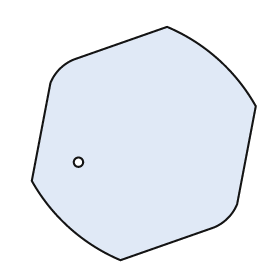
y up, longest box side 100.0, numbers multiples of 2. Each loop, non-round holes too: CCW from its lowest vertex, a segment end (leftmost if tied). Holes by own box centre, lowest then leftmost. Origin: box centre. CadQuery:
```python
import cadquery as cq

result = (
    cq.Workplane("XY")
    .moveTo(-10.0, -50.0)
    .lineTo(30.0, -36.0)
    .threePointArc((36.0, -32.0), (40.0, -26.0))
    .lineTo(48.0, 16.0)
    .threePointArc((32.0, 36.0), (10.0, 50.0))
    .lineTo(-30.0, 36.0)
    .threePointArc((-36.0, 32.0), (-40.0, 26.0))
    .lineTo(-48.0, -16.0)
    .threePointArc((-32.0, -36.0), (-10.0, -50.0))
    .close()
    .moveTo(-28.0, -8.0)
    .circle(2.0)
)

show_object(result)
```